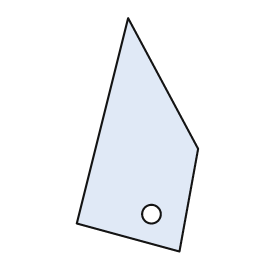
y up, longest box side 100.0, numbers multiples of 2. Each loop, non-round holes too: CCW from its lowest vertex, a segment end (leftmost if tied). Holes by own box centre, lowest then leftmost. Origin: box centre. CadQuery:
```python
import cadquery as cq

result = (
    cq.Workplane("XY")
    .moveTo(18.0, -50.0)
    .lineTo(26.0, -6.0)
    .lineTo(-4.0, 50.0)
    .lineTo(-26.0, -38.0)
    .close()
    .moveTo(6.0, -34.0)
    .circle(4.0)
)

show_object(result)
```